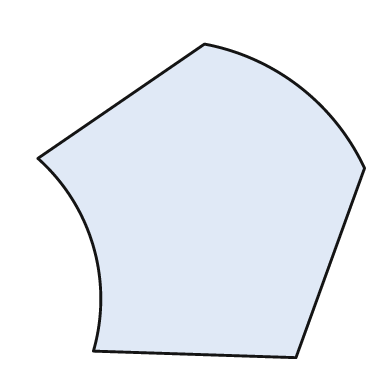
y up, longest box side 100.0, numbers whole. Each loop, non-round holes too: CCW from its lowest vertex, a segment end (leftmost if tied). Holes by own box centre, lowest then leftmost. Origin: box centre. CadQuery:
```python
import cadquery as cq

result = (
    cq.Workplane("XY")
    .moveTo(29.0, -48.0)
    .lineTo(50.0, 10.0)
    .threePointArc((30.0, 35.0), (1.0, 48.0))
    .lineTo(-50.0, 13.0)
    .threePointArc((-33.0, -14.0), (-33.0, -46.0))
    .close()
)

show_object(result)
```